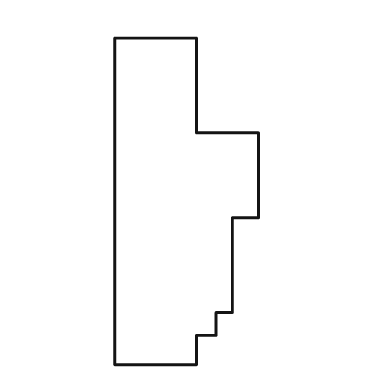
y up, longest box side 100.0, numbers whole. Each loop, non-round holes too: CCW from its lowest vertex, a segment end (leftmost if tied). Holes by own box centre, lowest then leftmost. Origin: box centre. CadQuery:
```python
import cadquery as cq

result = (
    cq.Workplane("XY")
    .moveTo(-22.0, -50.0)
    .lineTo(3.0, -50.0)
    .lineTo(3.0, -41.0)
    .lineTo(9.0, -41.0)
    .lineTo(9.0, -34.0)
    .lineTo(14.0, -34.0)
    .lineTo(14.0, -5.0)
    .lineTo(22.0, -5.0)
    .lineTo(22.0, 21.0)
    .lineTo(3.0, 21.0)
    .lineTo(3.0, 50.0)
    .lineTo(-22.0, 50.0)
    .close()
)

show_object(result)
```